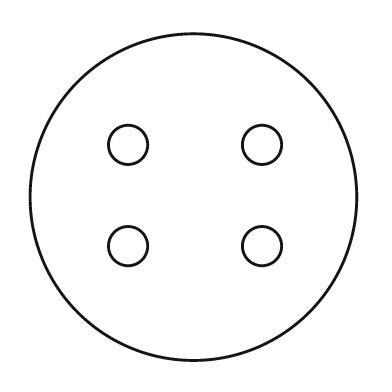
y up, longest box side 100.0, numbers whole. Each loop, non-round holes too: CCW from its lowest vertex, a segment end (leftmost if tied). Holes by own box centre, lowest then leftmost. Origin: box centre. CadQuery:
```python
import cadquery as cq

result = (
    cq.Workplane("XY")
    .moveTo(0.0, 0.0)
    .circle(50.0)
    .moveTo(-20.0, -15.0)
    .circle(6.0)
    .moveTo(21.0, -15.0)
    .circle(6.0)
    .moveTo(-20.0, 16.0)
    .circle(6.0)
    .moveTo(21.0, 16.0)
    .circle(6.0)
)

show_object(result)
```